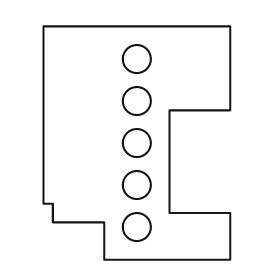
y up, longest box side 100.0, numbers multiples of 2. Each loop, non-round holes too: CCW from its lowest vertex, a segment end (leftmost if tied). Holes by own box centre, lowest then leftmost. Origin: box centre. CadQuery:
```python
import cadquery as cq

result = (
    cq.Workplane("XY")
    .moveTo(-14.0, -50.0)
    .lineTo(40.0, -50.0)
    .lineTo(40.0, -30.0)
    .lineTo(14.0, -30.0)
    .lineTo(14.0, 14.0)
    .lineTo(40.0, 14.0)
    .lineTo(40.0, 50.0)
    .lineTo(-40.0, 50.0)
    .lineTo(-40.0, -26.0)
    .lineTo(-36.0, -26.0)
    .lineTo(-36.0, -34.0)
    .lineTo(-14.0, -34.0)
    .close()
    .moveTo(0.0, -36.0)
    .circle(6.0)
    .moveTo(0.0, -18.0)
    .circle(6.0)
    .moveTo(0.0, 0.0)
    .circle(6.0)
    .moveTo(0.0, 18.0)
    .circle(6.0)
    .moveTo(0.0, 36.0)
    .circle(6.0)
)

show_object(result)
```